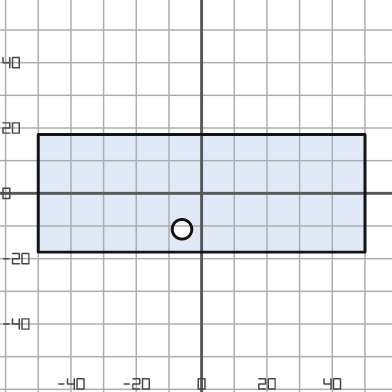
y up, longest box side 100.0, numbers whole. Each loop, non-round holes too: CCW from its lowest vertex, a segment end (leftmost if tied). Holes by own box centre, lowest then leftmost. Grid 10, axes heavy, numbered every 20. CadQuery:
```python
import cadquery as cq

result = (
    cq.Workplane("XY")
    .moveTo(-50.0, -18.0)
    .lineTo(50.0, -18.0)
    .lineTo(50.0, 18.0)
    .lineTo(-50.0, 18.0)
    .close()
    .moveTo(-6.0, -11.0)
    .circle(3.0)
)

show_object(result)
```